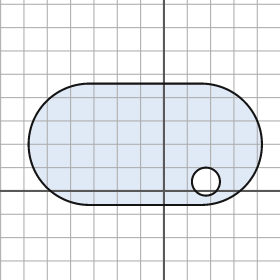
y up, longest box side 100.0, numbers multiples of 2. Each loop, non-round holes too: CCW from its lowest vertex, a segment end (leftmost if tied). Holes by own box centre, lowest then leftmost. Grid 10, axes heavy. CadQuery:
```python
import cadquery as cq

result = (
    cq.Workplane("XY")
    .moveTo(-32.0, -6.0)
    .lineTo(16.0, -6.0)
    .threePointArc((42.0, 20.0), (16.0, 46.0))
    .lineTo(-32.0, 46.0)
    .threePointArc((-58.0, 20.0), (-32.0, -6.0))
    .close()
    .moveTo(18.0, 4.0)
    .circle(6.0)
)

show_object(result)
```